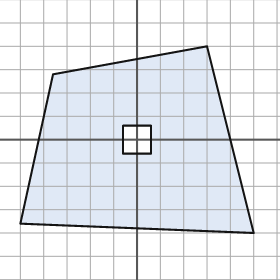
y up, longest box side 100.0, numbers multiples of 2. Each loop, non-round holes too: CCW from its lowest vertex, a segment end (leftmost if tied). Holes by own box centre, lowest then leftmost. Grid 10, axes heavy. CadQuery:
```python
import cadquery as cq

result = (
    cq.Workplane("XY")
    .moveTo(50.0, -40.0)
    .lineTo(30.0, 40.0)
    .lineTo(-36.0, 28.0)
    .lineTo(-50.0, -36.0)
    .close()
    .moveTo(-6.0, -6.0)
    .lineTo(6.0, -6.0)
    .lineTo(6.0, 6.0)
    .lineTo(-6.0, 6.0)
    .close()
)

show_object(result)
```